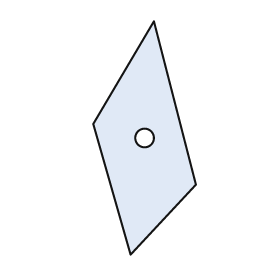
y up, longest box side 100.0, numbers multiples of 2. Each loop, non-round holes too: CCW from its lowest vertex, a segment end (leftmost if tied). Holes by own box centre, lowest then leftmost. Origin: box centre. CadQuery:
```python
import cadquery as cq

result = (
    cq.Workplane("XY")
    .moveTo(-6.0, -50.0)
    .lineTo(22.0, -20.0)
    .lineTo(4.0, 50.0)
    .lineTo(-22.0, 6.0)
    .close()
    .moveTo(0.0, 0.0)
    .circle(4.0)
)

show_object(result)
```